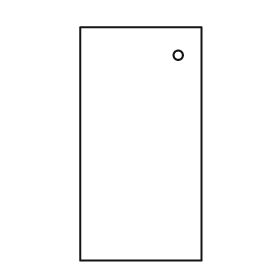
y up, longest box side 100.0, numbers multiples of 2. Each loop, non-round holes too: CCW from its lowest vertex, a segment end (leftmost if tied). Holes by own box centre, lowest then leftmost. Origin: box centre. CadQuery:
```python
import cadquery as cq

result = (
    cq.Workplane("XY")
    .moveTo(-26.0, -50.0)
    .lineTo(26.0, -50.0)
    .lineTo(26.0, 50.0)
    .lineTo(-26.0, 50.0)
    .close()
    .moveTo(16.0, 38.0)
    .circle(2.0)
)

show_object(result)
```